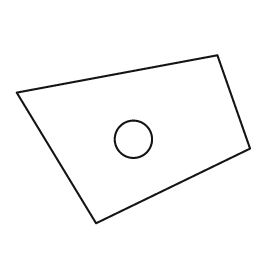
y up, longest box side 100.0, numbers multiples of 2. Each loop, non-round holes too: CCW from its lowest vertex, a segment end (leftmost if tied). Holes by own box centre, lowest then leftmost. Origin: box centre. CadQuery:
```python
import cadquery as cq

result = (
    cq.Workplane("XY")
    .moveTo(-16.0, -36.0)
    .lineTo(50.0, -4.0)
    .lineTo(36.0, 36.0)
    .lineTo(-50.0, 20.0)
    .close()
    .moveTo(0.0, 0.0)
    .circle(8.0)
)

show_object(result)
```